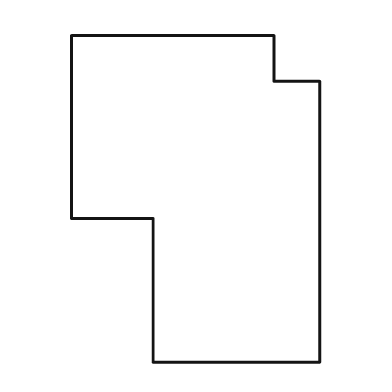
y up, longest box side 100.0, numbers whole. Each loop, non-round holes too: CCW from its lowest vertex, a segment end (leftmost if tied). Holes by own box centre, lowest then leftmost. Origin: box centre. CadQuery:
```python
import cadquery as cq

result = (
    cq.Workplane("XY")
    .moveTo(-13.0, -50.0)
    .lineTo(38.0, -50.0)
    .lineTo(38.0, 36.0)
    .lineTo(24.0, 36.0)
    .lineTo(24.0, 50.0)
    .lineTo(-38.0, 50.0)
    .lineTo(-38.0, -6.0)
    .lineTo(-13.0, -6.0)
    .close()
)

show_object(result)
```